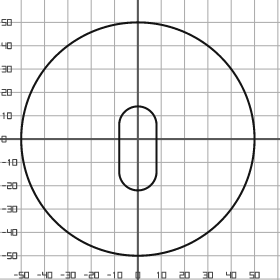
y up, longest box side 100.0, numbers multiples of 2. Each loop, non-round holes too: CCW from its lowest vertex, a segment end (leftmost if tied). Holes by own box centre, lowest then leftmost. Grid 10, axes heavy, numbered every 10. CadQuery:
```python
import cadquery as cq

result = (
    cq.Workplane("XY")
    .moveTo(0.0, 0.0)
    .circle(50.0)
    .moveTo(-8.0, -14.0)
    .threePointArc((0.0, -22.0), (8.0, -14.0))
    .lineTo(8.0, 6.0)
    .threePointArc((0.0, 14.0), (-8.0, 6.0))
    .close()
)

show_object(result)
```